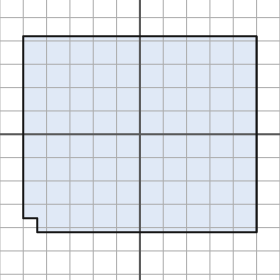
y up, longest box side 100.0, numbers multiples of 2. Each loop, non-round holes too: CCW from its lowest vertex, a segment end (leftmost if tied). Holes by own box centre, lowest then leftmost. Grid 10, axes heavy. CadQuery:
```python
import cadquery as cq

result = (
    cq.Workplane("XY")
    .moveTo(-44.0, -42.0)
    .lineTo(50.0, -42.0)
    .lineTo(50.0, 42.0)
    .lineTo(-50.0, 42.0)
    .lineTo(-50.0, -36.0)
    .lineTo(-44.0, -36.0)
    .close()
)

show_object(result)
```